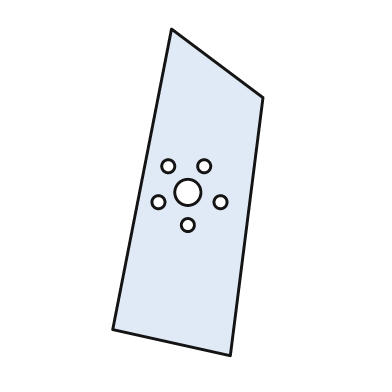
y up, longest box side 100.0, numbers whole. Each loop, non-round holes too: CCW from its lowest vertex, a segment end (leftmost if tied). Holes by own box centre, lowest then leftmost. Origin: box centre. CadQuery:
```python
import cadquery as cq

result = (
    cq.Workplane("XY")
    .moveTo(13.0, -50.0)
    .lineTo(23.0, 29.0)
    .lineTo(-5.0, 50.0)
    .lineTo(-23.0, -42.0)
    .close()
    .moveTo(0.0, -10.0)
    .circle(2.0)
    .moveTo(-9.0, -3.0)
    .circle(2.0)
    .moveTo(10.0, -3.0)
    .circle(2.0)
    .moveTo(0.0, 0.0)
    .circle(4.0)
    .moveTo(-6.0, 8.0)
    .circle(2.0)
    .moveTo(5.0, 8.0)
    .circle(2.0)
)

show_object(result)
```